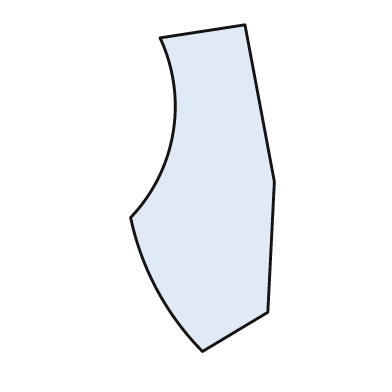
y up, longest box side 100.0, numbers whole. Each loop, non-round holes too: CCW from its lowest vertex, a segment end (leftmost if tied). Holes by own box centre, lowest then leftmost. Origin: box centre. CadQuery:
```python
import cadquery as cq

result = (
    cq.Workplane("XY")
    .moveTo(0.0, -50.0)
    .lineTo(20.0, -38.0)
    .lineTo(22.0, 2.0)
    .lineTo(13.0, 50.0)
    .lineTo(-13.0, 46.0)
    .threePointArc((-9.0, 17.0), (-22.0, -9.0))
    .threePointArc((-14.0, -31.0), (0.0, -50.0))
    .close()
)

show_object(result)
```